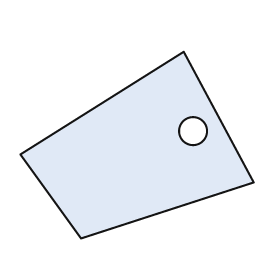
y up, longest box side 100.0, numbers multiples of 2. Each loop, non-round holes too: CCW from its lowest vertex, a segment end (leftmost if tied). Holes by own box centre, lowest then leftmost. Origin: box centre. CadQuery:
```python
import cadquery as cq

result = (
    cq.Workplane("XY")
    .moveTo(-24.0, -40.0)
    .lineTo(50.0, -16.0)
    .lineTo(20.0, 40.0)
    .lineTo(-50.0, -4.0)
    .close()
    .moveTo(24.0, 6.0)
    .circle(6.0)
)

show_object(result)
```